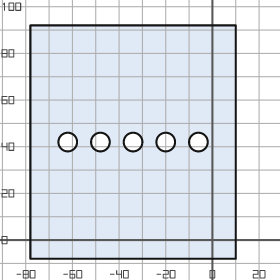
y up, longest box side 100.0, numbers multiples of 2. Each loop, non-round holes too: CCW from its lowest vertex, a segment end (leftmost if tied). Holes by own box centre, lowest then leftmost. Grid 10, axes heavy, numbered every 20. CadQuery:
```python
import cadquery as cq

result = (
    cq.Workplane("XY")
    .moveTo(-78.0, -8.0)
    .lineTo(10.0, -8.0)
    .lineTo(10.0, 92.0)
    .lineTo(-78.0, 92.0)
    .close()
    .moveTo(-62.0, 42.0)
    .circle(4.0)
    .moveTo(-48.0, 42.0)
    .circle(4.0)
    .moveTo(-34.0, 42.0)
    .circle(4.0)
    .moveTo(-20.0, 42.0)
    .circle(4.0)
    .moveTo(-6.0, 42.0)
    .circle(4.0)
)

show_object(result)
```